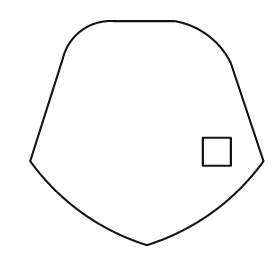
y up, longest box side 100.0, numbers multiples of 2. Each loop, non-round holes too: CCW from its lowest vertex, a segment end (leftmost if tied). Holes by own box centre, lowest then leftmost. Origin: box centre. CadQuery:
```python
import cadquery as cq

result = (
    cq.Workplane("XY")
    .moveTo(0.0, -48.0)
    .threePointArc((28.0, -34.0), (50.0, -12.0))
    .lineTo(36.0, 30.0)
    .threePointArc((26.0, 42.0), (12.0, 48.0))
    .lineTo(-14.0, 48.0)
    .threePointArc((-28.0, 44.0), (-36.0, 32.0))
    .lineTo(-50.0, -12.0)
    .threePointArc((-28.0, -34.0), (0.0, -48.0))
    .close()
    .moveTo(24.0, -14.0)
    .lineTo(36.0, -14.0)
    .lineTo(36.0, -2.0)
    .lineTo(24.0, -2.0)
    .close()
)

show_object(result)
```